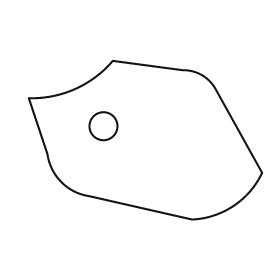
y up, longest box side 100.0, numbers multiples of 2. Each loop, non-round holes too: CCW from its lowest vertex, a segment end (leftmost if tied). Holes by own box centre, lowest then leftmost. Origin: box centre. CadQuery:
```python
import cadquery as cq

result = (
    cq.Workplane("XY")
    .moveTo(20.0, -34.0)
    .threePointArc((38.0, -28.0), (50.0, -14.0))
    .lineTo(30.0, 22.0)
    .threePointArc((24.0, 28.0), (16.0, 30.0))
    .lineTo(-14.0, 34.0)
    .threePointArc((-30.0, 22.0), (-50.0, 18.0))
    .lineTo(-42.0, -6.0)
    .threePointArc((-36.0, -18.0), (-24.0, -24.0))
    .close()
    .moveTo(-18.0, 6.0)
    .circle(6.0)
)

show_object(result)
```